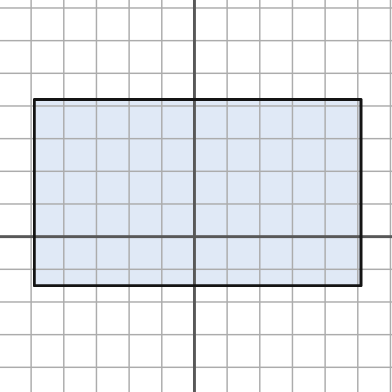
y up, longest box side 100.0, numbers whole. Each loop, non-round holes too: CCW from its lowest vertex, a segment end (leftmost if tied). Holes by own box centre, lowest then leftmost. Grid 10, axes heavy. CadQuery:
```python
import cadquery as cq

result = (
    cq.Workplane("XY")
    .moveTo(-49.0, -15.0)
    .lineTo(51.0, -15.0)
    .lineTo(51.0, 42.0)
    .lineTo(-49.0, 42.0)
    .close()
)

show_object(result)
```